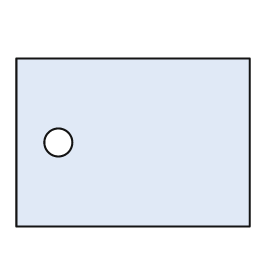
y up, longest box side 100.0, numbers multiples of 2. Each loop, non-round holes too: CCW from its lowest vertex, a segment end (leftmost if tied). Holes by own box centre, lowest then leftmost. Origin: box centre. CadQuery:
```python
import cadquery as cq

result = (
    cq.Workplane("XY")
    .moveTo(-50.0, -36.0)
    .lineTo(50.0, -36.0)
    .lineTo(50.0, 36.0)
    .lineTo(-50.0, 36.0)
    .close()
    .moveTo(-32.0, 0.0)
    .circle(6.0)
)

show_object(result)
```